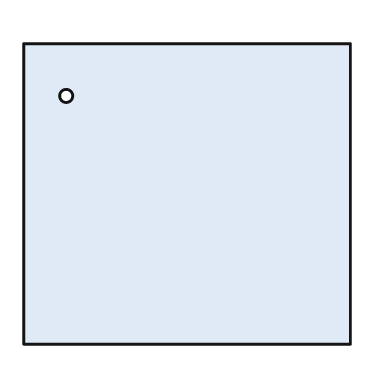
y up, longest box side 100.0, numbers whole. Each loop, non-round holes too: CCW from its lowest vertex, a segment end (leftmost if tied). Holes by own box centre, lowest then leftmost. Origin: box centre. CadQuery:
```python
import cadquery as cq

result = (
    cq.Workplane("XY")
    .moveTo(-50.0, -46.0)
    .lineTo(50.0, -46.0)
    .lineTo(50.0, 46.0)
    .lineTo(-50.0, 46.0)
    .close()
    .moveTo(-37.0, 30.0)
    .circle(2.0)
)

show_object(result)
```